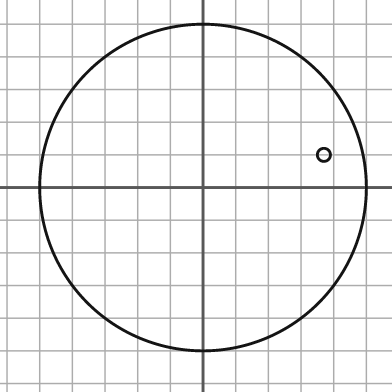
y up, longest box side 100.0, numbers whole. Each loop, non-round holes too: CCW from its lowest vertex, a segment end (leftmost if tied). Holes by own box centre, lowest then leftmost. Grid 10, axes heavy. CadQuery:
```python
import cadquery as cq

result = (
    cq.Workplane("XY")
    .moveTo(0.0, 0.0)
    .circle(50.0)
    .moveTo(37.0, 10.0)
    .circle(2.0)
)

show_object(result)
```